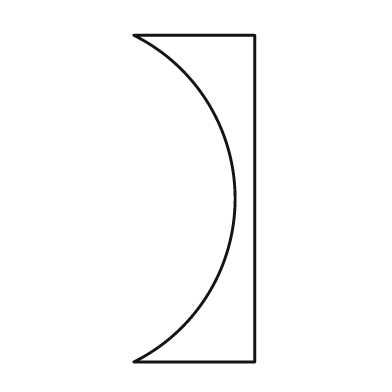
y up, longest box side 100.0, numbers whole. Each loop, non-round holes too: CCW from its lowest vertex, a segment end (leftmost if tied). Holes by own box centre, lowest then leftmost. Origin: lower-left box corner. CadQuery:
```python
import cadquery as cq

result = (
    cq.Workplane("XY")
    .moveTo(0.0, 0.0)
    .lineTo(37.0, 0.0)
    .lineTo(37.0, 100.0)
    .lineTo(0.0, 100.0)
    .threePointArc((31.0, 50.0), (0.0, 0.0))
    .close()
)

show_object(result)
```